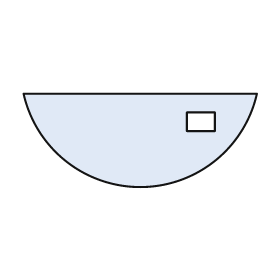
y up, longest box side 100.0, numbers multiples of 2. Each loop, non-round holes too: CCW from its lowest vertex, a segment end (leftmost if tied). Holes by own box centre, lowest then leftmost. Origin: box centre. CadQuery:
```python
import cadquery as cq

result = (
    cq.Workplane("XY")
    .moveTo(-50.0, 20.0)
    .threePointArc((0.0, -20.0), (50.0, 20.0))
    .close()
    .moveTo(20.0, 4.0)
    .lineTo(32.0, 4.0)
    .lineTo(32.0, 12.0)
    .lineTo(20.0, 12.0)
    .close()
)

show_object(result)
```